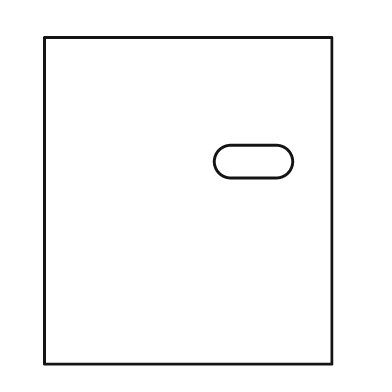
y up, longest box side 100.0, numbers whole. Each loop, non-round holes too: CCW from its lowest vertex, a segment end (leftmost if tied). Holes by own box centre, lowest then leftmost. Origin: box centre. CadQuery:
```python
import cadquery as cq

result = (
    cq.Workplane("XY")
    .moveTo(-44.0, -50.0)
    .lineTo(44.0, -50.0)
    .lineTo(44.0, 50.0)
    .lineTo(-44.0, 50.0)
    .close()
    .moveTo(13.0, 7.0)
    .lineTo(27.0, 7.0)
    .threePointArc((32.0, 12.0), (27.0, 17.0))
    .lineTo(13.0, 17.0)
    .threePointArc((8.0, 12.0), (13.0, 7.0))
    .close()
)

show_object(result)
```